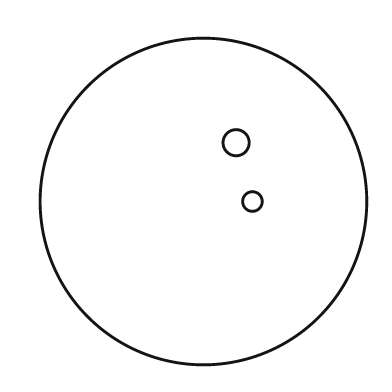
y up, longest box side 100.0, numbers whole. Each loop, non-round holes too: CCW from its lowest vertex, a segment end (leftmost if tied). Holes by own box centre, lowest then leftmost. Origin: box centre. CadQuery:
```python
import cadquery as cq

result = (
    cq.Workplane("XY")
    .moveTo(0.0, 0.0)
    .circle(50.0)
    .moveTo(15.0, 0.0)
    .circle(3.0)
    .moveTo(10.0, 18.0)
    .circle(4.0)
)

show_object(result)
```